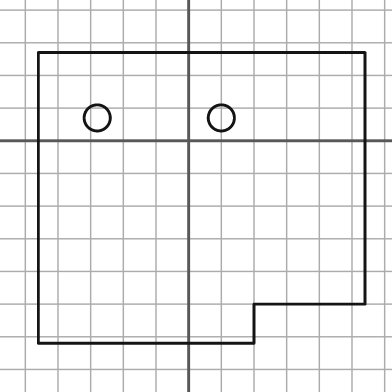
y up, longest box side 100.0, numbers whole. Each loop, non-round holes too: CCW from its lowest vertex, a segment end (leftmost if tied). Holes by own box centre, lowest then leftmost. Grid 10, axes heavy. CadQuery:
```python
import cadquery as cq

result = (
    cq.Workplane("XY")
    .moveTo(-46.0, -62.0)
    .lineTo(20.0, -62.0)
    .lineTo(20.0, -50.0)
    .lineTo(54.0, -50.0)
    .lineTo(54.0, 27.0)
    .lineTo(-46.0, 27.0)
    .close()
    .moveTo(-28.0, 7.0)
    .circle(4.0)
    .moveTo(10.0, 7.0)
    .circle(4.0)
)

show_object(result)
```